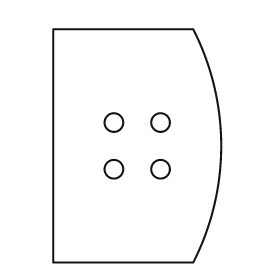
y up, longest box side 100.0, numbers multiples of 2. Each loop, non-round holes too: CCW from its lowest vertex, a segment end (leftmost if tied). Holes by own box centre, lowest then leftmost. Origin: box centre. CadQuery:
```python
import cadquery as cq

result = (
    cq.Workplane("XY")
    .moveTo(-36.0, -50.0)
    .lineTo(24.0, -50.0)
    .threePointArc((36.0, 0.0), (24.0, 50.0))
    .lineTo(-36.0, 50.0)
    .close()
    .moveTo(-10.0, -10.0)
    .circle(4.0)
    .moveTo(10.0, -10.0)
    .circle(4.0)
    .moveTo(-10.0, 10.0)
    .circle(4.0)
    .moveTo(10.0, 10.0)
    .circle(4.0)
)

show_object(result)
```